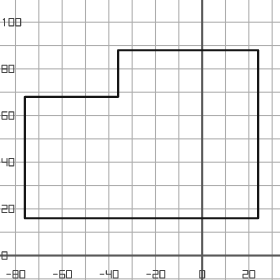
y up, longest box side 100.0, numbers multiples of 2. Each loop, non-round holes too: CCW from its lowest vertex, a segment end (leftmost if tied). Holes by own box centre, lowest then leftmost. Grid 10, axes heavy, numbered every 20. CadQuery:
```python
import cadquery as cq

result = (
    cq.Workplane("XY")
    .moveTo(-76.0, 16.0)
    .lineTo(24.0, 16.0)
    .lineTo(24.0, 88.0)
    .lineTo(-36.0, 88.0)
    .lineTo(-36.0, 68.0)
    .lineTo(-76.0, 68.0)
    .close()
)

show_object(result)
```